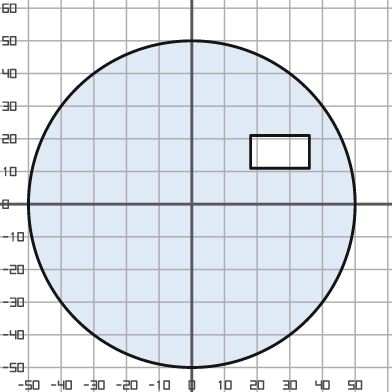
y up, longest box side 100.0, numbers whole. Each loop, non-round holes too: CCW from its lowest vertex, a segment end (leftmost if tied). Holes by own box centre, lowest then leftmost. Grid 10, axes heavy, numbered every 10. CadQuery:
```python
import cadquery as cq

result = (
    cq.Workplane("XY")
    .moveTo(0.0, 0.0)
    .circle(50.0)
    .moveTo(18.0, 11.0)
    .lineTo(36.0, 11.0)
    .lineTo(36.0, 21.0)
    .lineTo(18.0, 21.0)
    .close()
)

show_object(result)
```